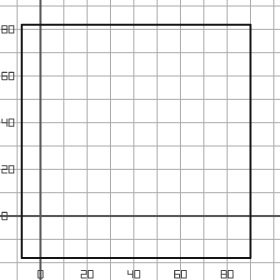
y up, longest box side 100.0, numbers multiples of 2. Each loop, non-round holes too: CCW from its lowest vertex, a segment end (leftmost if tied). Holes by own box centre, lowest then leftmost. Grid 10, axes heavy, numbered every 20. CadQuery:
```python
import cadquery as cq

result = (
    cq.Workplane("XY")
    .moveTo(-8.0, -18.0)
    .lineTo(90.0, -18.0)
    .lineTo(90.0, 82.0)
    .lineTo(-8.0, 82.0)
    .close()
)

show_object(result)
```